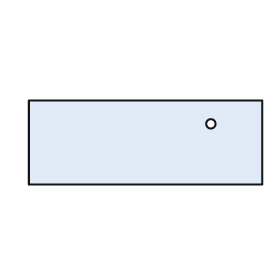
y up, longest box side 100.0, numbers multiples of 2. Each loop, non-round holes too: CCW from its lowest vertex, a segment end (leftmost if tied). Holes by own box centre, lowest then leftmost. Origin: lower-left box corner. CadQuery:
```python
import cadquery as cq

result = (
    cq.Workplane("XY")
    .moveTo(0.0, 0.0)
    .lineTo(100.0, 0.0)
    .lineTo(100.0, 36.0)
    .lineTo(0.0, 36.0)
    .close()
    .moveTo(78.0, 26.0)
    .circle(2.0)
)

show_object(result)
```